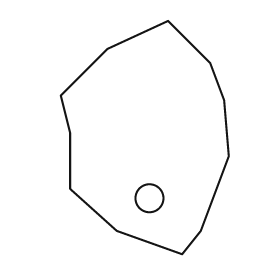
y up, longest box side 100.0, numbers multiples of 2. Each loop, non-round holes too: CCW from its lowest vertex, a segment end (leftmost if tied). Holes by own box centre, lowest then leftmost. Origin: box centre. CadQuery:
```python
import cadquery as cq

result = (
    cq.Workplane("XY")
    .moveTo(16.0, -50.0)
    .lineTo(24.0, -40.0)
    .lineTo(36.0, -8.0)
    .lineTo(34.0, 16.0)
    .lineTo(28.0, 32.0)
    .lineTo(10.0, 50.0)
    .lineTo(-16.0, 38.0)
    .lineTo(-36.0, 18.0)
    .lineTo(-32.0, 2.0)
    .lineTo(-32.0, -22.0)
    .lineTo(-12.0, -40.0)
    .close()
    .moveTo(2.0, -26.0)
    .circle(6.0)
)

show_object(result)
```